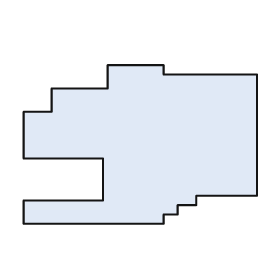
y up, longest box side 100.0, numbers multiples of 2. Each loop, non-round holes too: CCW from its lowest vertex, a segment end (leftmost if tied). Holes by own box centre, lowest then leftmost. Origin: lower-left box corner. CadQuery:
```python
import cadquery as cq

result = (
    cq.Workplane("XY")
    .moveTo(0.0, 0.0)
    .lineTo(60.0, 0.0)
    .lineTo(60.0, 4.0)
    .lineTo(66.0, 4.0)
    .lineTo(66.0, 8.0)
    .lineTo(74.0, 8.0)
    .lineTo(74.0, 12.0)
    .lineTo(100.0, 12.0)
    .lineTo(100.0, 64.0)
    .lineTo(60.0, 64.0)
    .lineTo(60.0, 68.0)
    .lineTo(36.0, 68.0)
    .lineTo(36.0, 58.0)
    .lineTo(12.0, 58.0)
    .lineTo(12.0, 48.0)
    .lineTo(0.0, 48.0)
    .lineTo(0.0, 28.0)
    .lineTo(34.0, 28.0)
    .lineTo(34.0, 10.0)
    .lineTo(0.0, 10.0)
    .close()
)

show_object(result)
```